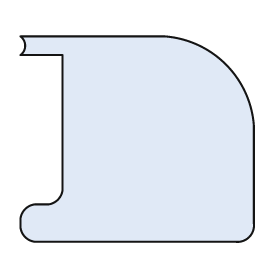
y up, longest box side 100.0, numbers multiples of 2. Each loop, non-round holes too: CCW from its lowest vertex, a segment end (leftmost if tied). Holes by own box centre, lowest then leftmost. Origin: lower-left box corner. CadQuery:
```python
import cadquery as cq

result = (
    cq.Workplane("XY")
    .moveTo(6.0, 0.0)
    .lineTo(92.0, 0.0)
    .threePointArc((98.0, 2.0), (100.0, 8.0))
    .lineTo(100.0, 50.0)
    .threePointArc((88.0, 76.0), (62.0, 88.0))
    .lineTo(0.0, 88.0)
    .threePointArc((2.0, 84.0), (0.0, 80.0))
    .lineTo(18.0, 80.0)
    .lineTo(18.0, 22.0)
    .threePointArc((16.0, 18.0), (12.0, 16.0))
    .lineTo(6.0, 16.0)
    .threePointArc((2.0, 14.0), (0.0, 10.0))
    .lineTo(0.0, 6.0)
    .threePointArc((2.0, 2.0), (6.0, 0.0))
    .close()
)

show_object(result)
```